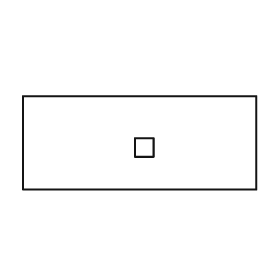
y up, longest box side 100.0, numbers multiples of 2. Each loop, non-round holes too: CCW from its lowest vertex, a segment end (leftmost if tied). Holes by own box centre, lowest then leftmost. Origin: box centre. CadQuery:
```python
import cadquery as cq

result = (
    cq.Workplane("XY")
    .moveTo(-50.0, -20.0)
    .lineTo(50.0, -20.0)
    .lineTo(50.0, 20.0)
    .lineTo(-50.0, 20.0)
    .close()
    .moveTo(-2.0, -6.0)
    .lineTo(6.0, -6.0)
    .lineTo(6.0, 2.0)
    .lineTo(-2.0, 2.0)
    .close()
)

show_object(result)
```